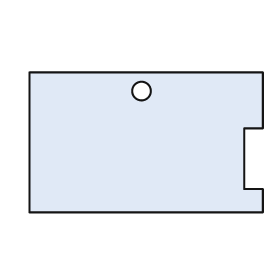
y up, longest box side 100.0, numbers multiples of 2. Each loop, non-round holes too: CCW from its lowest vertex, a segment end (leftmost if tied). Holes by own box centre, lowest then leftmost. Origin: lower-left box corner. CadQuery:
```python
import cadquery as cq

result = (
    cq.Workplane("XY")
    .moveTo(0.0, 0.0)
    .lineTo(100.0, 0.0)
    .lineTo(100.0, 10.0)
    .lineTo(92.0, 10.0)
    .lineTo(92.0, 36.0)
    .lineTo(100.0, 36.0)
    .lineTo(100.0, 60.0)
    .lineTo(0.0, 60.0)
    .close()
    .moveTo(48.0, 52.0)
    .circle(4.0)
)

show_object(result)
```